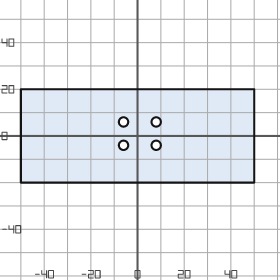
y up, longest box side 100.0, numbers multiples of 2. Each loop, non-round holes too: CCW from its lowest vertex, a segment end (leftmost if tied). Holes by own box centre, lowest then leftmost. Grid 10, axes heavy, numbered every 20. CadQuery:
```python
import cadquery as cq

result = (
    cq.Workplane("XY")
    .moveTo(-50.0, -20.0)
    .lineTo(50.0, -20.0)
    .lineTo(50.0, 20.0)
    .lineTo(-50.0, 20.0)
    .close()
    .moveTo(-6.0, -4.0)
    .circle(2.0)
    .moveTo(8.0, -4.0)
    .circle(2.0)
    .moveTo(-6.0, 6.0)
    .circle(2.0)
    .moveTo(8.0, 6.0)
    .circle(2.0)
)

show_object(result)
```